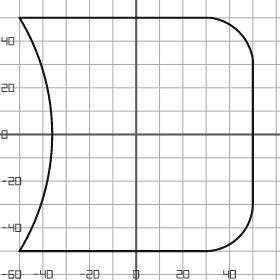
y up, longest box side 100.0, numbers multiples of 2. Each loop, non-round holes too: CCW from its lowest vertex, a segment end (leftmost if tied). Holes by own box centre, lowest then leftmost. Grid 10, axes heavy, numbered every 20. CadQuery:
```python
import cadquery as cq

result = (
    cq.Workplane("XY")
    .moveTo(-50.0, -50.0)
    .lineTo(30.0, -50.0)
    .threePointArc((44.0, -44.0), (50.0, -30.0))
    .lineTo(50.0, 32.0)
    .threePointArc((44.0, 44.0), (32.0, 50.0))
    .lineTo(-50.0, 50.0)
    .threePointArc((-36.0, 0.0), (-50.0, -50.0))
    .close()
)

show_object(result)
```